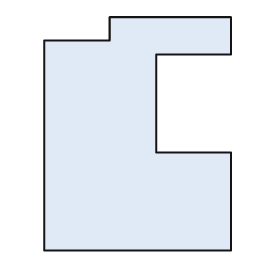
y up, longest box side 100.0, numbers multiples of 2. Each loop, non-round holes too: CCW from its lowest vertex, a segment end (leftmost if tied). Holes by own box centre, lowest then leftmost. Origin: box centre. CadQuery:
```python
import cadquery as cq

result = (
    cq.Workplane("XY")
    .moveTo(-40.0, -50.0)
    .lineTo(40.0, -50.0)
    .lineTo(40.0, -8.0)
    .lineTo(8.0, -8.0)
    .lineTo(8.0, 34.0)
    .lineTo(40.0, 34.0)
    .lineTo(40.0, 50.0)
    .lineTo(-12.0, 50.0)
    .lineTo(-12.0, 40.0)
    .lineTo(-40.0, 40.0)
    .close()
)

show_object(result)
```